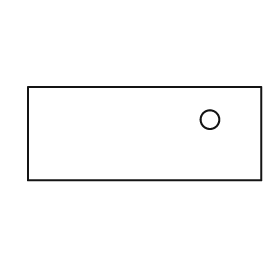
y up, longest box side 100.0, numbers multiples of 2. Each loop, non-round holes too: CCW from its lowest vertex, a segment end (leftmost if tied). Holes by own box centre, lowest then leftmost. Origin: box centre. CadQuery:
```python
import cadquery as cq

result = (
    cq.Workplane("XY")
    .moveTo(-50.0, -20.0)
    .lineTo(50.0, -20.0)
    .lineTo(50.0, 20.0)
    .lineTo(-50.0, 20.0)
    .close()
    .moveTo(28.0, 6.0)
    .circle(4.0)
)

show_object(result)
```